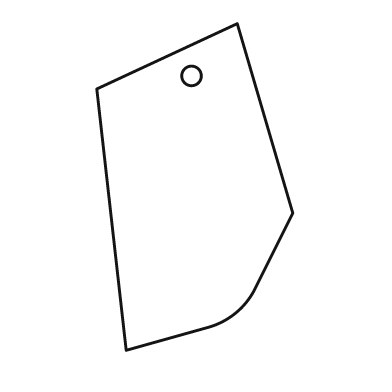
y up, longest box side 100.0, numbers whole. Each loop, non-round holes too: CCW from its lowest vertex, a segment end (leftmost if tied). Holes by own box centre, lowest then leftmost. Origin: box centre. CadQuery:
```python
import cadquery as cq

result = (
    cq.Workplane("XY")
    .moveTo(-21.0, -50.0)
    .lineTo(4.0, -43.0)
    .threePointArc((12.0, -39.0), (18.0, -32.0))
    .lineTo(30.0, -8.0)
    .lineTo(13.0, 50.0)
    .lineTo(-30.0, 30.0)
    .close()
    .moveTo(-1.0, 34.0)
    .circle(3.0)
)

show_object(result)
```